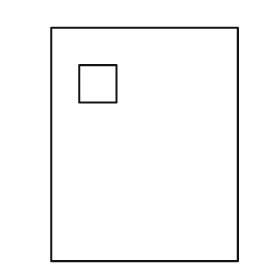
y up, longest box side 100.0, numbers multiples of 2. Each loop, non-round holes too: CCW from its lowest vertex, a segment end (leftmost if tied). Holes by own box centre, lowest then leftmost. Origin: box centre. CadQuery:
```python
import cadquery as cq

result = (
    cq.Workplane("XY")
    .moveTo(-40.0, -50.0)
    .lineTo(40.0, -50.0)
    .lineTo(40.0, 50.0)
    .lineTo(-40.0, 50.0)
    .close()
    .moveTo(-28.0, 18.0)
    .lineTo(-12.0, 18.0)
    .lineTo(-12.0, 34.0)
    .lineTo(-28.0, 34.0)
    .close()
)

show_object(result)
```